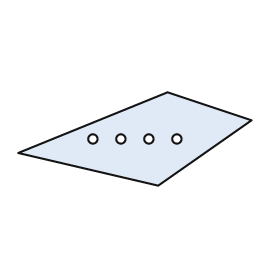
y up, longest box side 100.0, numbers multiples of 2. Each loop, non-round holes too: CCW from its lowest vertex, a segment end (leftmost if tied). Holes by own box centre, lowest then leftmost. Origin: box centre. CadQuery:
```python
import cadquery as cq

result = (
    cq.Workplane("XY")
    .moveTo(10.0, -20.0)
    .lineTo(50.0, 8.0)
    .lineTo(14.0, 20.0)
    .lineTo(-50.0, -6.0)
    .close()
    .moveTo(-18.0, 0.0)
    .circle(2.0)
    .moveTo(-6.0, 0.0)
    .circle(2.0)
    .moveTo(6.0, 0.0)
    .circle(2.0)
    .moveTo(18.0, 0.0)
    .circle(2.0)
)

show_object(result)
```